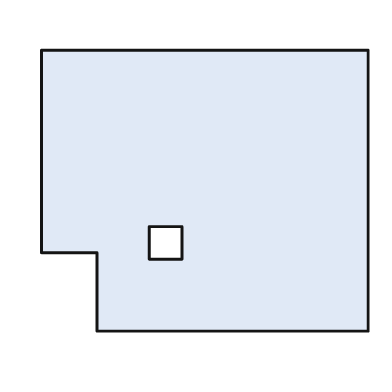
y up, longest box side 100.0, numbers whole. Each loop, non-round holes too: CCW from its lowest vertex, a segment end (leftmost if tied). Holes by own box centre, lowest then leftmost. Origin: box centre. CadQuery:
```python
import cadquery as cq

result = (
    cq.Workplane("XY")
    .moveTo(-33.0, -43.0)
    .lineTo(50.0, -43.0)
    .lineTo(50.0, 43.0)
    .lineTo(-50.0, 43.0)
    .lineTo(-50.0, -19.0)
    .lineTo(-33.0, -19.0)
    .close()
    .moveTo(-17.0, -21.0)
    .lineTo(-7.0, -21.0)
    .lineTo(-7.0, -11.0)
    .lineTo(-17.0, -11.0)
    .close()
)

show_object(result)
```